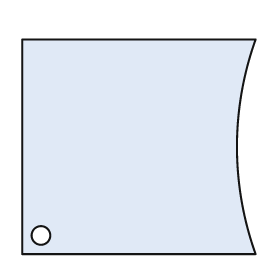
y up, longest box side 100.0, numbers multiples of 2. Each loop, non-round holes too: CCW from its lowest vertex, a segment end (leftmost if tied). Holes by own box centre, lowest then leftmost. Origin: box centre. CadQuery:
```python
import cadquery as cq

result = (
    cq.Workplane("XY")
    .moveTo(-50.0, -46.0)
    .lineTo(50.0, -46.0)
    .threePointArc((42.0, 0.0), (50.0, 46.0))
    .lineTo(-50.0, 46.0)
    .close()
    .moveTo(-42.0, -38.0)
    .circle(4.0)
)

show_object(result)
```